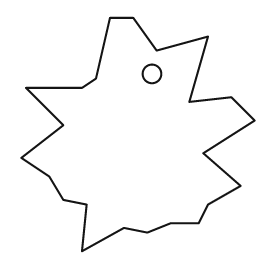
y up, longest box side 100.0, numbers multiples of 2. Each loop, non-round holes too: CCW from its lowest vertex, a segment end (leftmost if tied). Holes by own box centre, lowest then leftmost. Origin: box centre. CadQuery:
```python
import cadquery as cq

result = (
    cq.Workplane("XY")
    .moveTo(-24.0, -50.0)
    .lineTo(-6.0, -40.0)
    .lineTo(4.0, -42.0)
    .lineTo(14.0, -38.0)
    .lineTo(26.0, -38.0)
    .lineTo(30.0, -30.0)
    .lineTo(44.0, -22.0)
    .lineTo(28.0, -8.0)
    .lineTo(50.0, 6.0)
    .lineTo(40.0, 16.0)
    .lineTo(22.0, 14.0)
    .lineTo(30.0, 42.0)
    .lineTo(8.0, 36.0)
    .lineTo(-2.0, 50.0)
    .lineTo(-12.0, 50.0)
    .lineTo(-18.0, 24.0)
    .lineTo(-24.0, 20.0)
    .lineTo(-48.0, 20.0)
    .lineTo(-32.0, 4.0)
    .lineTo(-50.0, -10.0)
    .lineTo(-38.0, -18.0)
    .lineTo(-32.0, -28.0)
    .lineTo(-22.0, -30.0)
    .close()
    .moveTo(6.0, 26.0)
    .circle(4.0)
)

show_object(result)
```